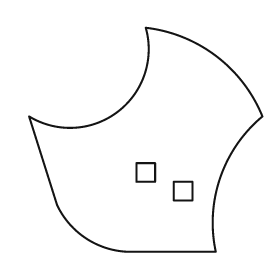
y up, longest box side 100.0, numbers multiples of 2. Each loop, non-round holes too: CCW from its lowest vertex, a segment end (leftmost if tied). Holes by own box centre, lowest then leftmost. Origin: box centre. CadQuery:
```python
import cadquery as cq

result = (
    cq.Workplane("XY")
    .moveTo(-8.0, -48.0)
    .lineTo(30.0, -48.0)
    .threePointArc((32.0, -16.0), (50.0, 10.0))
    .threePointArc((30.0, 36.0), (0.0, 48.0))
    .threePointArc((-12.0, 12.0), (-50.0, 10.0))
    .lineTo(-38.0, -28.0)
    .threePointArc((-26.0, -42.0), (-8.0, -48.0))
    .close()
    .moveTo(12.0, -26.0)
    .lineTo(20.0, -26.0)
    .lineTo(20.0, -18.0)
    .lineTo(12.0, -18.0)
    .close()
    .moveTo(-4.0, -18.0)
    .lineTo(4.0, -18.0)
    .lineTo(4.0, -10.0)
    .lineTo(-4.0, -10.0)
    .close()
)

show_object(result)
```